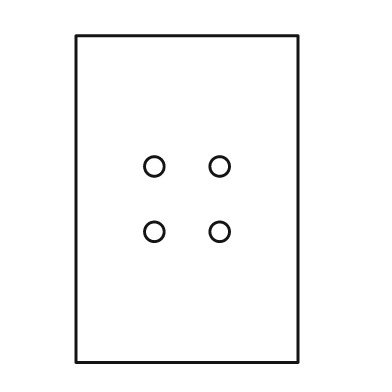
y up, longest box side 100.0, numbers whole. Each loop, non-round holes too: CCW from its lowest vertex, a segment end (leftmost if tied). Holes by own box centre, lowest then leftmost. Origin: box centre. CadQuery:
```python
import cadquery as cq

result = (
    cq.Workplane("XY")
    .moveTo(-34.0, -50.0)
    .lineTo(34.0, -50.0)
    .lineTo(34.0, 50.0)
    .lineTo(-34.0, 50.0)
    .close()
    .moveTo(-10.0, -10.0)
    .circle(3.0)
    .moveTo(10.0, -10.0)
    .circle(3.0)
    .moveTo(-10.0, 10.0)
    .circle(3.0)
    .moveTo(10.0, 10.0)
    .circle(3.0)
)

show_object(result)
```